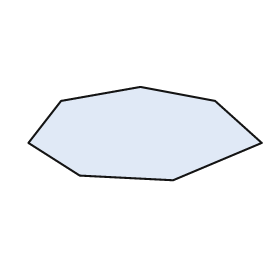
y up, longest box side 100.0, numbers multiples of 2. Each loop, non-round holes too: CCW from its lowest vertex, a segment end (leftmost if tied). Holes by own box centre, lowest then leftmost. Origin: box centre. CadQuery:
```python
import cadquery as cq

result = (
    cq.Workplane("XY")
    .moveTo(12.0, -20.0)
    .lineTo(50.0, -4.0)
    .lineTo(30.0, 14.0)
    .lineTo(-2.0, 20.0)
    .lineTo(-36.0, 14.0)
    .lineTo(-50.0, -4.0)
    .lineTo(-28.0, -18.0)
    .close()
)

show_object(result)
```